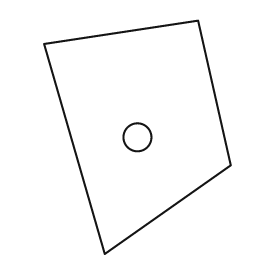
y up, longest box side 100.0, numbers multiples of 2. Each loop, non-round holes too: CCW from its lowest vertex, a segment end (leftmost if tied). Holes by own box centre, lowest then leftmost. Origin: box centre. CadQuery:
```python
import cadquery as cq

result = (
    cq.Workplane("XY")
    .moveTo(-14.0, -50.0)
    .lineTo(40.0, -12.0)
    .lineTo(26.0, 50.0)
    .lineTo(-40.0, 40.0)
    .close()
    .moveTo(0.0, 0.0)
    .circle(6.0)
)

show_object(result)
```